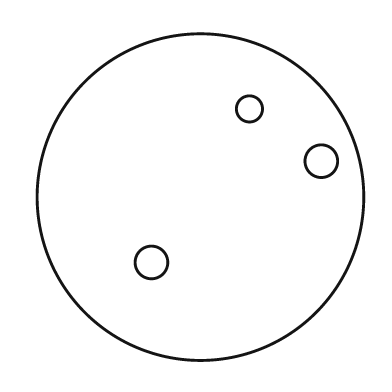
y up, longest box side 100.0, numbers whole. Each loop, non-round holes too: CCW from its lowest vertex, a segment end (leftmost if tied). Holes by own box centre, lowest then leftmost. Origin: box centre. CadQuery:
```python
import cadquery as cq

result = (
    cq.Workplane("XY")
    .moveTo(0.0, 0.0)
    .circle(50.0)
    .moveTo(-15.0, -20.0)
    .circle(5.0)
    .moveTo(37.0, 11.0)
    .circle(5.0)
    .moveTo(15.0, 27.0)
    .circle(4.0)
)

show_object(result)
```